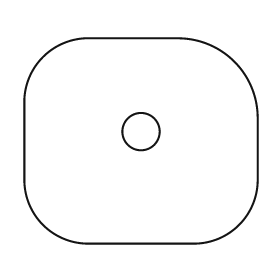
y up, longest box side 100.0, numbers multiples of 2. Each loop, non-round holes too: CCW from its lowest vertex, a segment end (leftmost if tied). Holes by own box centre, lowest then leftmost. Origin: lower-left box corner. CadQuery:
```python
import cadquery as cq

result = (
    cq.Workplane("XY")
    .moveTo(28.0, 0.0)
    .lineTo(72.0, 0.0)
    .threePointArc((92.0, 8.0), (100.0, 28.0))
    .lineTo(100.0, 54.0)
    .threePointArc((90.0, 78.0), (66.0, 88.0))
    .lineTo(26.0, 88.0)
    .threePointArc((8.0, 80.0), (0.0, 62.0))
    .lineTo(0.0, 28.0)
    .threePointArc((8.0, 8.0), (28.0, 0.0))
    .close()
    .moveTo(50.0, 48.0)
    .circle(8.0)
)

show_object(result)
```